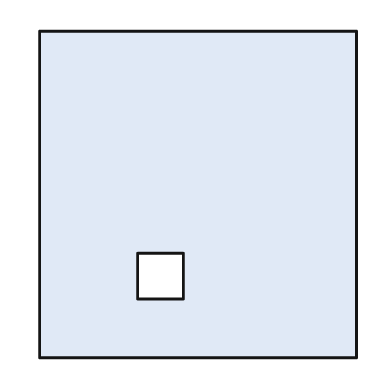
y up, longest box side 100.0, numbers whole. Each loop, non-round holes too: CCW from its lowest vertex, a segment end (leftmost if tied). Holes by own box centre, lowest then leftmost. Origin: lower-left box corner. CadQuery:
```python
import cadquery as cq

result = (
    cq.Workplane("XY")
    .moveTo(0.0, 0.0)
    .lineTo(97.0, 0.0)
    .lineTo(97.0, 100.0)
    .lineTo(0.0, 100.0)
    .close()
    .moveTo(30.0, 18.0)
    .lineTo(44.0, 18.0)
    .lineTo(44.0, 32.0)
    .lineTo(30.0, 32.0)
    .close()
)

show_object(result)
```